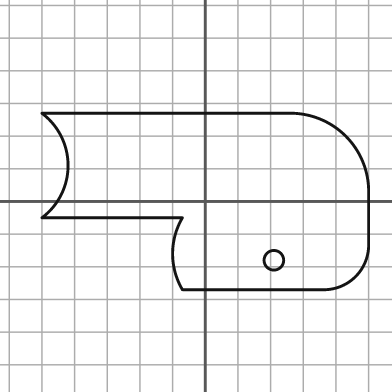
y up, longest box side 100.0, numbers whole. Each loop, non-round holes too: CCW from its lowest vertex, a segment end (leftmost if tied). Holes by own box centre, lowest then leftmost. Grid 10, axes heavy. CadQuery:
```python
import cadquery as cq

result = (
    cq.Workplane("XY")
    .moveTo(-7.0, -27.0)
    .lineTo(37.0, -27.0)
    .threePointArc((46.0, -23.0), (50.0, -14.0))
    .lineTo(50.0, 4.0)
    .threePointArc((43.0, 20.0), (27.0, 27.0))
    .lineTo(-50.0, 27.0)
    .threePointArc((-42.0, 11.0), (-50.0, -5.0))
    .lineTo(-7.0, -5.0)
    .threePointArc((-10.0, -16.0), (-7.0, -27.0))
    .close()
    .moveTo(21.0, -18.0)
    .circle(3.0)
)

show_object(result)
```